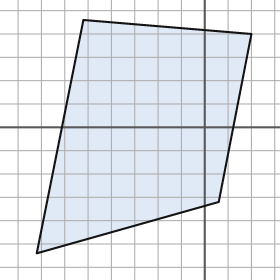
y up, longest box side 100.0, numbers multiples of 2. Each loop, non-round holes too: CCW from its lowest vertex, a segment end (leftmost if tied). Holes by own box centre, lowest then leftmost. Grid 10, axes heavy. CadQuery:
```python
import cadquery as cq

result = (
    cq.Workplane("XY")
    .moveTo(-72.0, -54.0)
    .lineTo(6.0, -32.0)
    .lineTo(20.0, 40.0)
    .lineTo(-52.0, 46.0)
    .close()
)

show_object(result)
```